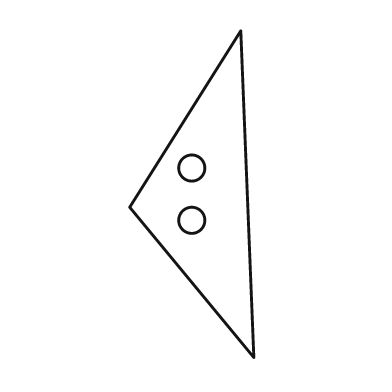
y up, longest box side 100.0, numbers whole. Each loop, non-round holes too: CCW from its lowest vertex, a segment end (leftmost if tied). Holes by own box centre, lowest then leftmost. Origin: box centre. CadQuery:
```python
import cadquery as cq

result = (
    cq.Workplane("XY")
    .moveTo(19.0, -50.0)
    .lineTo(15.0, 50.0)
    .lineTo(-19.0, -4.0)
    .close()
    .moveTo(0.0, -8.0)
    .circle(4.0)
    .moveTo(0.0, 8.0)
    .circle(4.0)
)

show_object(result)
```